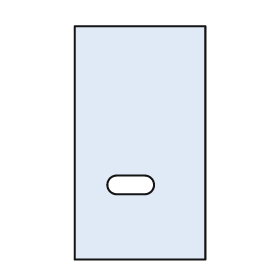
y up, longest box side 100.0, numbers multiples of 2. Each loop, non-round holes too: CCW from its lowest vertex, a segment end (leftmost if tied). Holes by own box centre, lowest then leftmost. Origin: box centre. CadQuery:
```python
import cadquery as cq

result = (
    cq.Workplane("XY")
    .moveTo(-28.0, -50.0)
    .lineTo(28.0, -50.0)
    .lineTo(28.0, 50.0)
    .lineTo(-28.0, 50.0)
    .close()
    .moveTo(-10.0, -22.0)
    .lineTo(2.0, -22.0)
    .threePointArc((6.0, -18.0), (2.0, -14.0))
    .lineTo(-10.0, -14.0)
    .threePointArc((-14.0, -18.0), (-10.0, -22.0))
    .close()
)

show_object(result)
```